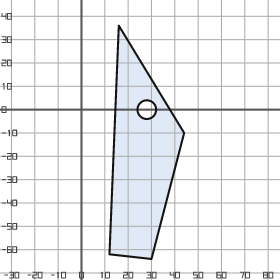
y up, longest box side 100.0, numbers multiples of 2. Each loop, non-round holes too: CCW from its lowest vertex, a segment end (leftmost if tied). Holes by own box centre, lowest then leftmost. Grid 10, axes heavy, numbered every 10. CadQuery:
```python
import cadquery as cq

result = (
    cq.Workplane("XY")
    .moveTo(30.0, -64.0)
    .lineTo(44.0, -10.0)
    .lineTo(16.0, 36.0)
    .lineTo(12.0, -62.0)
    .close()
    .moveTo(28.0, 0.0)
    .circle(4.0)
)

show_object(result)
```